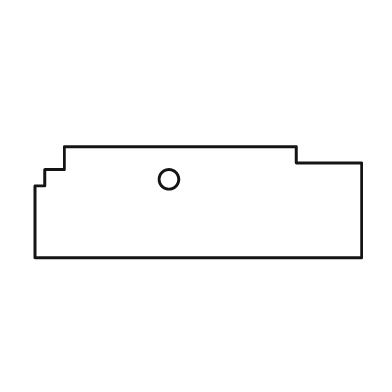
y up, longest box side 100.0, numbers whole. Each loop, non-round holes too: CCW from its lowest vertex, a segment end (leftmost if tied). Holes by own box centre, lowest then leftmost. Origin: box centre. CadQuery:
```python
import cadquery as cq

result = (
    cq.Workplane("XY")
    .moveTo(-50.0, -17.0)
    .lineTo(50.0, -17.0)
    .lineTo(50.0, 12.0)
    .lineTo(30.0, 12.0)
    .lineTo(30.0, 17.0)
    .lineTo(-41.0, 17.0)
    .lineTo(-41.0, 10.0)
    .lineTo(-47.0, 10.0)
    .lineTo(-47.0, 5.0)
    .lineTo(-50.0, 5.0)
    .close()
    .moveTo(-9.0, 7.0)
    .circle(3.0)
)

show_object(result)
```